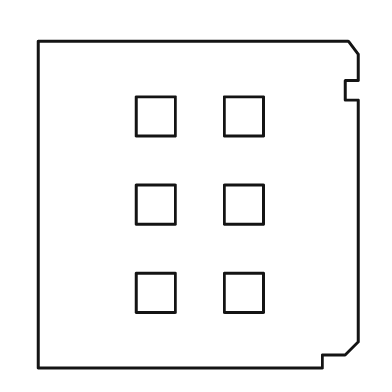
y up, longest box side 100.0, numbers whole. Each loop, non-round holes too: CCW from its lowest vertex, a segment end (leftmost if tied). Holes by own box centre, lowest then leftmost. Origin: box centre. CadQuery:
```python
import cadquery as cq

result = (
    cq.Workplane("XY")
    .moveTo(-49.0, -50.0)
    .lineTo(38.0, -50.0)
    .lineTo(38.0, -46.0)
    .lineTo(45.0, -46.0)
    .lineTo(49.0, -42.0)
    .lineTo(49.0, 32.0)
    .lineTo(45.0, 32.0)
    .lineTo(45.0, 38.0)
    .lineTo(49.0, 38.0)
    .lineTo(49.0, 46.0)
    .lineTo(46.0, 50.0)
    .lineTo(-49.0, 50.0)
    .close()
    .moveTo(-19.0, -33.0)
    .lineTo(-7.0, -33.0)
    .lineTo(-7.0, -21.0)
    .lineTo(-19.0, -21.0)
    .close()
    .moveTo(8.0, -33.0)
    .lineTo(20.0, -33.0)
    .lineTo(20.0, -21.0)
    .lineTo(8.0, -21.0)
    .close()
    .moveTo(-19.0, -6.0)
    .lineTo(-7.0, -6.0)
    .lineTo(-7.0, 6.0)
    .lineTo(-19.0, 6.0)
    .close()
    .moveTo(8.0, -6.0)
    .lineTo(20.0, -6.0)
    .lineTo(20.0, 6.0)
    .lineTo(8.0, 6.0)
    .close()
    .moveTo(-19.0, 21.0)
    .lineTo(-7.0, 21.0)
    .lineTo(-7.0, 33.0)
    .lineTo(-19.0, 33.0)
    .close()
    .moveTo(8.0, 21.0)
    .lineTo(20.0, 21.0)
    .lineTo(20.0, 33.0)
    .lineTo(8.0, 33.0)
    .close()
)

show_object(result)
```